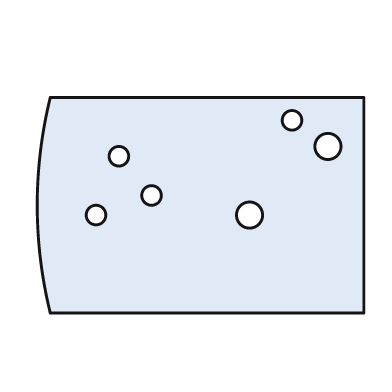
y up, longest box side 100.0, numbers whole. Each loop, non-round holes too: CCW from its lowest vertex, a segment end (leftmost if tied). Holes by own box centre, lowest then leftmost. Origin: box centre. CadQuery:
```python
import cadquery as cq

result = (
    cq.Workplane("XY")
    .moveTo(-46.0, -33.0)
    .lineTo(50.0, -33.0)
    .lineTo(50.0, 33.0)
    .lineTo(-46.0, 33.0)
    .threePointArc((-50.0, 0.0), (-46.0, -33.0))
    .close()
    .moveTo(-32.0, -3.0)
    .circle(3.0)
    .moveTo(15.0, -3.0)
    .circle(4.0)
    .moveTo(-15.0, 3.0)
    .circle(3.0)
    .moveTo(-25.0, 15.0)
    .circle(3.0)
    .moveTo(39.0, 18.0)
    .circle(4.0)
    .moveTo(28.0, 26.0)
    .circle(3.0)
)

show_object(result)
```